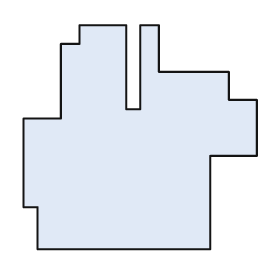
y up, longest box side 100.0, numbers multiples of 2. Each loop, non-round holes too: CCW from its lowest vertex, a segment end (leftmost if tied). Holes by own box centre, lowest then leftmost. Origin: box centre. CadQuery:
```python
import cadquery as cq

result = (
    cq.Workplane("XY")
    .moveTo(-44.0, -48.0)
    .lineTo(30.0, -48.0)
    .lineTo(30.0, -8.0)
    .lineTo(50.0, -8.0)
    .lineTo(50.0, 16.0)
    .lineTo(38.0, 16.0)
    .lineTo(38.0, 28.0)
    .lineTo(8.0, 28.0)
    .lineTo(8.0, 48.0)
    .lineTo(0.0, 48.0)
    .lineTo(0.0, 12.0)
    .lineTo(-6.0, 12.0)
    .lineTo(-6.0, 48.0)
    .lineTo(-26.0, 48.0)
    .lineTo(-26.0, 40.0)
    .lineTo(-34.0, 40.0)
    .lineTo(-34.0, 8.0)
    .lineTo(-50.0, 8.0)
    .lineTo(-50.0, -30.0)
    .lineTo(-44.0, -30.0)
    .close()
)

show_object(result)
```